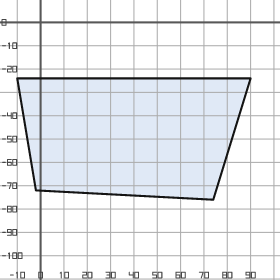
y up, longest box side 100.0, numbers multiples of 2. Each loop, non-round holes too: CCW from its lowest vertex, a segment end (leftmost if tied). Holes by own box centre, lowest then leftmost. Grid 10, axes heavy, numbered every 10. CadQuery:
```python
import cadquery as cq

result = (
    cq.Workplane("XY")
    .moveTo(74.0, -76.0)
    .lineTo(90.0, -24.0)
    .lineTo(-10.0, -24.0)
    .lineTo(-2.0, -72.0)
    .close()
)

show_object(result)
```